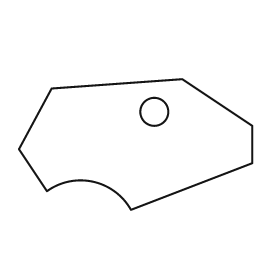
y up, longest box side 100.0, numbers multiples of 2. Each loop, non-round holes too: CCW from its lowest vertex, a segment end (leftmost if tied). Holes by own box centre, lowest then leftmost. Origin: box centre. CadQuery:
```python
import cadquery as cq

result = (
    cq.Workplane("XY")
    .moveTo(-2.0, -28.0)
    .lineTo(50.0, -8.0)
    .lineTo(50.0, 8.0)
    .lineTo(20.0, 28.0)
    .lineTo(-36.0, 24.0)
    .lineTo(-50.0, -2.0)
    .lineTo(-38.0, -20.0)
    .threePointArc((-18.0, -16.0), (-2.0, -28.0))
    .close()
    .moveTo(8.0, 14.0)
    .circle(6.0)
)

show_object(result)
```